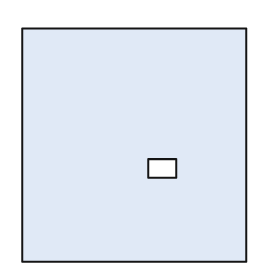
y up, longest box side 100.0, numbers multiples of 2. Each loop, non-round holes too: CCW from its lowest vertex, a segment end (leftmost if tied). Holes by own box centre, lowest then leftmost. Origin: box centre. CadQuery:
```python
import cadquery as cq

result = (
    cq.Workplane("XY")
    .moveTo(-48.0, -50.0)
    .lineTo(48.0, -50.0)
    .lineTo(48.0, 50.0)
    .lineTo(-48.0, 50.0)
    .close()
    .moveTo(6.0, -14.0)
    .lineTo(18.0, -14.0)
    .lineTo(18.0, -6.0)
    .lineTo(6.0, -6.0)
    .close()
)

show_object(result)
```